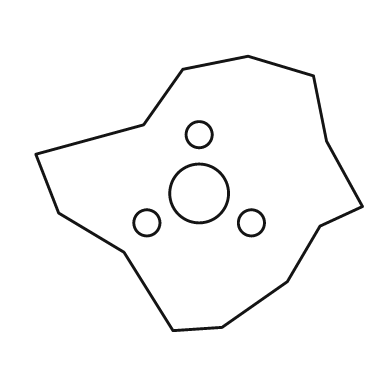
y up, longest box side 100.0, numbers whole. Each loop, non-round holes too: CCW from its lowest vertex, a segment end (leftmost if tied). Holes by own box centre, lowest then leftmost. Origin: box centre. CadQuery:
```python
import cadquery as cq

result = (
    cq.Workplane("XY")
    .moveTo(-8.0, -42.0)
    .lineTo(7.0, -41.0)
    .lineTo(27.0, -27.0)
    .lineTo(37.0, -10.0)
    .lineTo(50.0, -4.0)
    .lineTo(39.0, 16.0)
    .lineTo(35.0, 36.0)
    .lineTo(15.0, 42.0)
    .lineTo(-5.0, 38.0)
    .lineTo(-17.0, 21.0)
    .lineTo(-50.0, 12.0)
    .lineTo(-43.0, -6.0)
    .lineTo(-23.0, -18.0)
    .close()
    .moveTo(-16.0, -9.0)
    .circle(4.0)
    .moveTo(16.0, -9.0)
    .circle(4.0)
    .moveTo(0.0, 0.0)
    .circle(9.0)
    .moveTo(0.0, 18.0)
    .circle(4.0)
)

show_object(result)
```